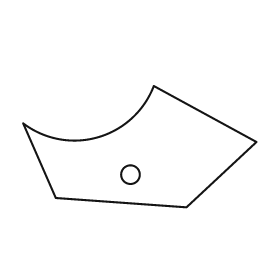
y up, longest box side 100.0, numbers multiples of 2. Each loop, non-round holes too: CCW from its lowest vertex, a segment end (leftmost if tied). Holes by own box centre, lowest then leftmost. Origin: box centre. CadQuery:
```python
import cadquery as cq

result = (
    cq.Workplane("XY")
    .moveTo(20.0, -26.0)
    .lineTo(50.0, 2.0)
    .lineTo(6.0, 26.0)
    .threePointArc((-18.0, 4.0), (-50.0, 10.0))
    .lineTo(-36.0, -22.0)
    .close()
    .moveTo(-4.0, -12.0)
    .circle(4.0)
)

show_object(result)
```